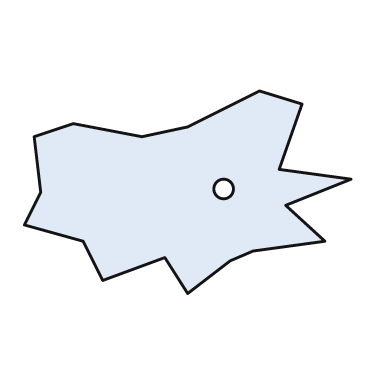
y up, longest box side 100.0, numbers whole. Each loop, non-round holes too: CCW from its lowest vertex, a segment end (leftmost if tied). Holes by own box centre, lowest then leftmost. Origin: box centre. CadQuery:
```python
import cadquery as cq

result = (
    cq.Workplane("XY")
    .moveTo(0.0, -31.0)
    .lineTo(13.0, -21.0)
    .lineTo(20.0, -18.0)
    .lineTo(42.0, -15.0)
    .lineTo(30.0, -4.0)
    .lineTo(50.0, 4.0)
    .lineTo(28.0, 7.0)
    .lineTo(35.0, 27.0)
    .lineTo(22.0, 31.0)
    .lineTo(0.0, 20.0)
    .lineTo(-14.0, 17.0)
    .lineTo(-35.0, 21.0)
    .lineTo(-47.0, 17.0)
    .lineTo(-45.0, 0.0)
    .lineTo(-50.0, -10.0)
    .lineTo(-32.0, -15.0)
    .lineTo(-26.0, -27.0)
    .lineTo(-7.0, -20.0)
    .close()
    .moveTo(11.0, 1.0)
    .circle(3.0)
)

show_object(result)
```